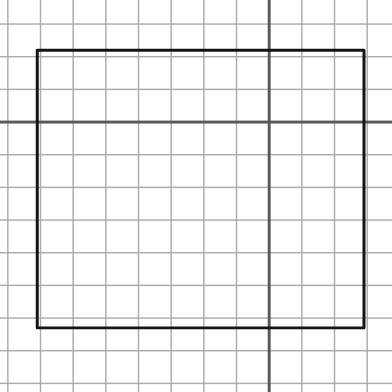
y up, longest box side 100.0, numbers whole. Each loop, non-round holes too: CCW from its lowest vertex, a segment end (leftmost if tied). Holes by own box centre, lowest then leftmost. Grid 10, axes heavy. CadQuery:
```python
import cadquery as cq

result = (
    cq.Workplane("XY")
    .moveTo(-71.0, -63.0)
    .lineTo(29.0, -63.0)
    .lineTo(29.0, 22.0)
    .lineTo(-71.0, 22.0)
    .close()
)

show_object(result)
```